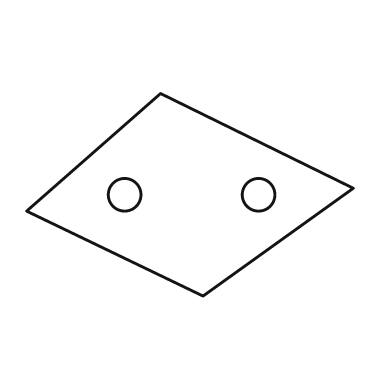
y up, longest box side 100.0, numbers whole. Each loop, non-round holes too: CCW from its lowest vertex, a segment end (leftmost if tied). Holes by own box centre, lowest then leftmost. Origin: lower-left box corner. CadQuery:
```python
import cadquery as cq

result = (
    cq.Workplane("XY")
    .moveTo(54.0, 0.0)
    .lineTo(100.0, 33.0)
    .lineTo(41.0, 62.0)
    .lineTo(0.0, 26.0)
    .close()
    .moveTo(30.0, 31.0)
    .circle(5.0)
    .moveTo(71.0, 31.0)
    .circle(5.0)
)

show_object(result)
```